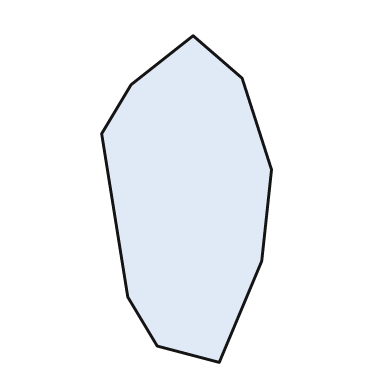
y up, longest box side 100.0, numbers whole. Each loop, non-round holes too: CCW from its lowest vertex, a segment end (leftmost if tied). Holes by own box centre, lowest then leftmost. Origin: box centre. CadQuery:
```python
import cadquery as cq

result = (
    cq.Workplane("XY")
    .moveTo(10.0, -50.0)
    .lineTo(23.0, -19.0)
    .lineTo(26.0, 9.0)
    .lineTo(17.0, 37.0)
    .lineTo(2.0, 50.0)
    .lineTo(-17.0, 35.0)
    .lineTo(-26.0, 20.0)
    .lineTo(-18.0, -30.0)
    .lineTo(-9.0, -45.0)
    .close()
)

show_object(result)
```